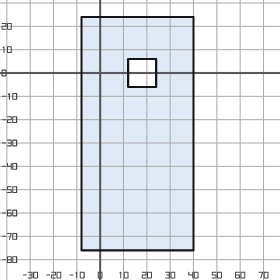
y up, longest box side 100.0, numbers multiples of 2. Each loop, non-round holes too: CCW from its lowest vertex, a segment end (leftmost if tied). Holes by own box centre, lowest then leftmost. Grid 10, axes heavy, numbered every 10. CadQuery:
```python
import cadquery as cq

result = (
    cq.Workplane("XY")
    .moveTo(-8.0, -76.0)
    .lineTo(40.0, -76.0)
    .lineTo(40.0, 24.0)
    .lineTo(-8.0, 24.0)
    .close()
    .moveTo(12.0, -6.0)
    .lineTo(24.0, -6.0)
    .lineTo(24.0, 6.0)
    .lineTo(12.0, 6.0)
    .close()
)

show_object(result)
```